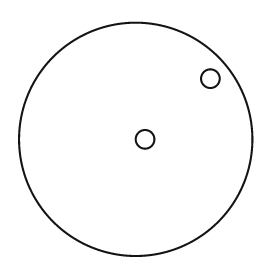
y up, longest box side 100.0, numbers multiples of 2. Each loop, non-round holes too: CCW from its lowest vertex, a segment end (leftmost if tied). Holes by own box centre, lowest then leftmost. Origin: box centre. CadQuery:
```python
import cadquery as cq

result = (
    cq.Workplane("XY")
    .moveTo(0.0, 0.0)
    .circle(50.0)
    .moveTo(4.0, 0.0)
    .circle(4.0)
    .moveTo(32.0, 26.0)
    .circle(4.0)
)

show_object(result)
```